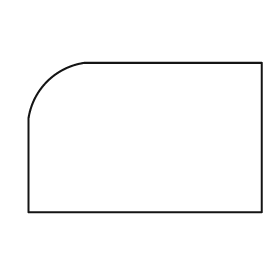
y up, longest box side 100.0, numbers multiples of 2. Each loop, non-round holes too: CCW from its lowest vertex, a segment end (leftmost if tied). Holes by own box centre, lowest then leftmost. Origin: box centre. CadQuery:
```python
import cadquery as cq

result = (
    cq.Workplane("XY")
    .moveTo(-50.0, -32.0)
    .lineTo(50.0, -32.0)
    .lineTo(50.0, 32.0)
    .lineTo(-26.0, 32.0)
    .threePointArc((-42.0, 24.0), (-50.0, 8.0))
    .close()
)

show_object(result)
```